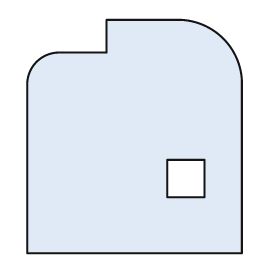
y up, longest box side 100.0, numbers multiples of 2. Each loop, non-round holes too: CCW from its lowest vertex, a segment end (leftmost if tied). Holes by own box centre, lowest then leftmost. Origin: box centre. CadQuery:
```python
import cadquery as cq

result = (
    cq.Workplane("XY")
    .moveTo(-46.0, -50.0)
    .lineTo(46.0, -50.0)
    .lineTo(46.0, 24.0)
    .threePointArc((38.0, 42.0), (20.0, 50.0))
    .lineTo(-12.0, 50.0)
    .lineTo(-12.0, 36.0)
    .lineTo(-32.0, 36.0)
    .threePointArc((-42.0, 32.0), (-46.0, 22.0))
    .close()
    .moveTo(14.0, -26.0)
    .lineTo(30.0, -26.0)
    .lineTo(30.0, -10.0)
    .lineTo(14.0, -10.0)
    .close()
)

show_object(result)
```